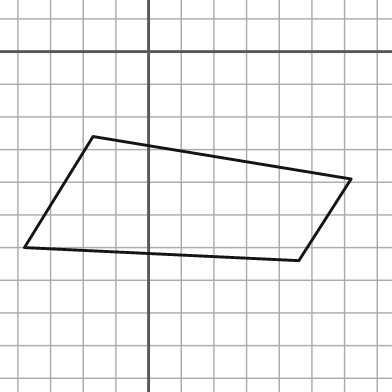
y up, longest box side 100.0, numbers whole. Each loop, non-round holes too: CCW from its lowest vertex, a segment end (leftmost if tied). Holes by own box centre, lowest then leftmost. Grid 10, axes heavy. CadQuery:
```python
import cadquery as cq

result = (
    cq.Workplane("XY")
    .moveTo(46.0, -64.0)
    .lineTo(62.0, -39.0)
    .lineTo(-17.0, -26.0)
    .lineTo(-38.0, -60.0)
    .close()
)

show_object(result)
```